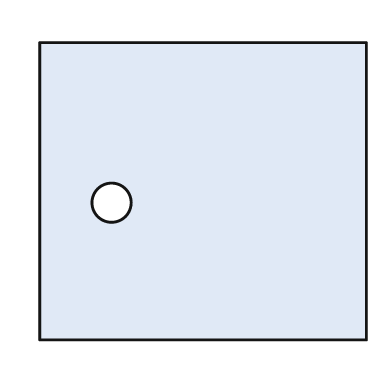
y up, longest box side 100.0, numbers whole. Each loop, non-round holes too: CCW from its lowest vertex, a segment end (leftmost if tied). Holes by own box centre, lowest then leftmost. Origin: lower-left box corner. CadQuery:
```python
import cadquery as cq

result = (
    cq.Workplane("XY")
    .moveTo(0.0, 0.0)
    .lineTo(100.0, 0.0)
    .lineTo(100.0, 91.0)
    .lineTo(0.0, 91.0)
    .close()
    .moveTo(22.0, 42.0)
    .circle(6.0)
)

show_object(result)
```